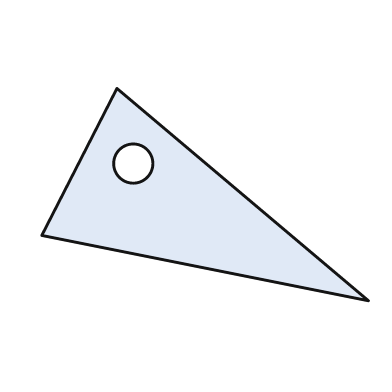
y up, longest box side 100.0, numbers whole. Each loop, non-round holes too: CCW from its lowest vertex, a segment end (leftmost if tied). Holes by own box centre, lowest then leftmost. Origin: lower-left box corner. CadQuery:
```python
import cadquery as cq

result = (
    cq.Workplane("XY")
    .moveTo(100.0, 0.0)
    .lineTo(23.0, 65.0)
    .lineTo(0.0, 20.0)
    .close()
    .moveTo(28.0, 42.0)
    .circle(6.0)
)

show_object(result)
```